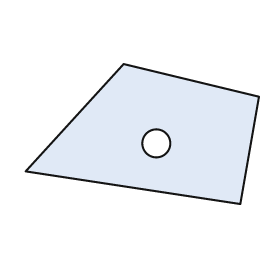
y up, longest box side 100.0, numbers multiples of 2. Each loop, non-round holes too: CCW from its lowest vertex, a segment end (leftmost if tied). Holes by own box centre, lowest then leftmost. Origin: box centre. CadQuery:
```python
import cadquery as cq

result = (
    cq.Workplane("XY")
    .moveTo(42.0, -30.0)
    .lineTo(50.0, 16.0)
    .lineTo(-8.0, 30.0)
    .lineTo(-50.0, -16.0)
    .close()
    .moveTo(6.0, -4.0)
    .circle(6.0)
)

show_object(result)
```